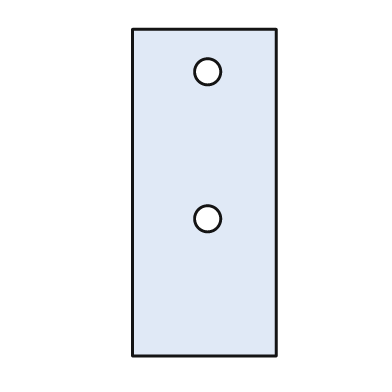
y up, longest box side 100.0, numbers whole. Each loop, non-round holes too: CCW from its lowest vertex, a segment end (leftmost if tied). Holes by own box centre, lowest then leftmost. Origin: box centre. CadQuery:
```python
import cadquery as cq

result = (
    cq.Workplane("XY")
    .moveTo(-22.0, -50.0)
    .lineTo(22.0, -50.0)
    .lineTo(22.0, 50.0)
    .lineTo(-22.0, 50.0)
    .close()
    .moveTo(1.0, -8.0)
    .circle(4.0)
    .moveTo(1.0, 37.0)
    .circle(4.0)
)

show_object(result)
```